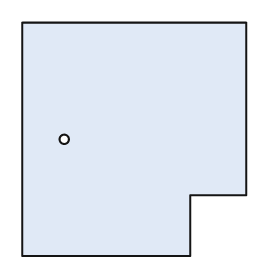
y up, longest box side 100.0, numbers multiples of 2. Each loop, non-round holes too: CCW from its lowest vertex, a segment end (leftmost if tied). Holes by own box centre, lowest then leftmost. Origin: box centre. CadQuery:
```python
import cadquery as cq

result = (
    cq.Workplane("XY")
    .moveTo(-48.0, -50.0)
    .lineTo(24.0, -50.0)
    .lineTo(24.0, -24.0)
    .lineTo(48.0, -24.0)
    .lineTo(48.0, 50.0)
    .lineTo(-48.0, 50.0)
    .close()
    .moveTo(-30.0, 0.0)
    .circle(2.0)
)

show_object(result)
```